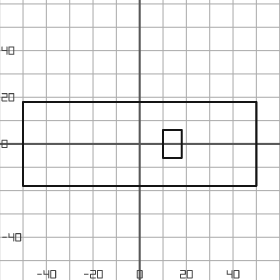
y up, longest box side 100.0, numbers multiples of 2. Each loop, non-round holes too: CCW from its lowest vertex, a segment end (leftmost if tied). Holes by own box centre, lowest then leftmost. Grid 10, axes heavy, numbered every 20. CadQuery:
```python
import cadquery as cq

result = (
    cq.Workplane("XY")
    .moveTo(-50.0, -18.0)
    .lineTo(50.0, -18.0)
    .lineTo(50.0, 18.0)
    .lineTo(-50.0, 18.0)
    .close()
    .moveTo(10.0, -6.0)
    .lineTo(18.0, -6.0)
    .lineTo(18.0, 6.0)
    .lineTo(10.0, 6.0)
    .close()
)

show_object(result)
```